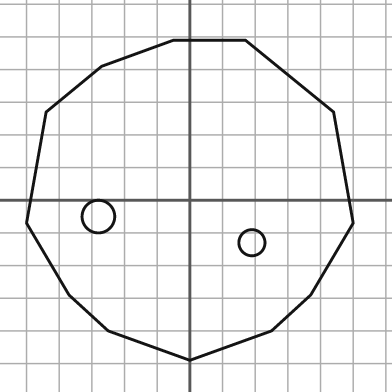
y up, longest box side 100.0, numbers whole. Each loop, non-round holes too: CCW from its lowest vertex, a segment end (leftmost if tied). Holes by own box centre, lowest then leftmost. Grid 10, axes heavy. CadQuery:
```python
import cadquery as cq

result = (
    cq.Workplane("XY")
    .moveTo(0.0, -49.0)
    .lineTo(25.0, -40.0)
    .lineTo(37.0, -29.0)
    .lineTo(50.0, -7.0)
    .lineTo(44.0, 27.0)
    .lineTo(17.0, 49.0)
    .lineTo(-5.0, 49.0)
    .lineTo(-27.0, 41.0)
    .lineTo(-44.0, 27.0)
    .lineTo(-50.0, -7.0)
    .lineTo(-37.0, -29.0)
    .lineTo(-25.0, -40.0)
    .close()
    .moveTo(19.0, -13.0)
    .circle(4.0)
    .moveTo(-28.0, -5.0)
    .circle(5.0)
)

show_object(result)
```